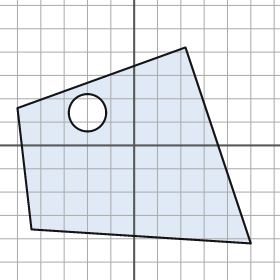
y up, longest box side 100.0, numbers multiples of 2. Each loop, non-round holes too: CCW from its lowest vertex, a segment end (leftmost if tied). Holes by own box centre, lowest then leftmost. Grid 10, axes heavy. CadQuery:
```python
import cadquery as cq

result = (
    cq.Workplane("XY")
    .moveTo(50.0, -42.0)
    .lineTo(22.0, 42.0)
    .lineTo(-50.0, 16.0)
    .lineTo(-44.0, -36.0)
    .close()
    .moveTo(-20.0, 14.0)
    .circle(8.0)
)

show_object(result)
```